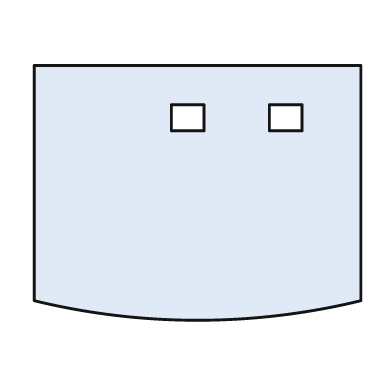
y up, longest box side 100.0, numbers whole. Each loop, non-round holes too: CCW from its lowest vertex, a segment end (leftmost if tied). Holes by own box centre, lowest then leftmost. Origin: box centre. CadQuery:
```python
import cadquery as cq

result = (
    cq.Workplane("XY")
    .moveTo(-50.0, -33.0)
    .threePointArc((0.0, -39.0), (50.0, -33.0))
    .lineTo(50.0, 39.0)
    .lineTo(-50.0, 39.0)
    .close()
    .moveTo(-8.0, 19.0)
    .lineTo(2.0, 19.0)
    .lineTo(2.0, 27.0)
    .lineTo(-8.0, 27.0)
    .close()
    .moveTo(22.0, 19.0)
    .lineTo(32.0, 19.0)
    .lineTo(32.0, 27.0)
    .lineTo(22.0, 27.0)
    .close()
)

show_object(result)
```